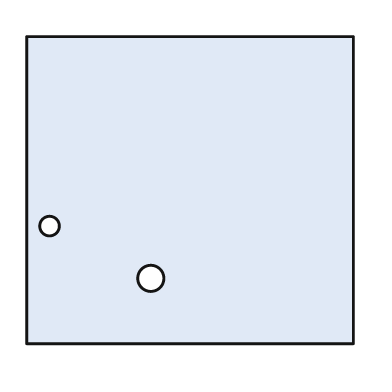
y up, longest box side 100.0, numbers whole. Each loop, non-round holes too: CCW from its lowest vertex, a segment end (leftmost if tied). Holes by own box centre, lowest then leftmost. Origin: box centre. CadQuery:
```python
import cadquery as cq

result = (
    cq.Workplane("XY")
    .moveTo(-50.0, -47.0)
    .lineTo(50.0, -47.0)
    .lineTo(50.0, 47.0)
    .lineTo(-50.0, 47.0)
    .close()
    .moveTo(-12.0, -27.0)
    .circle(4.0)
    .moveTo(-43.0, -11.0)
    .circle(3.0)
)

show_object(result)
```